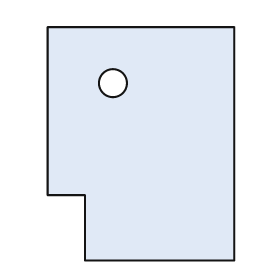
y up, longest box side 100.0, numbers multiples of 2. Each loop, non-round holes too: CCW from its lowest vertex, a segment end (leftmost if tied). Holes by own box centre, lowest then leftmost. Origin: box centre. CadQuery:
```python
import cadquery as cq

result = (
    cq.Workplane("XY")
    .moveTo(-24.0, -50.0)
    .lineTo(40.0, -50.0)
    .lineTo(40.0, 50.0)
    .lineTo(-40.0, 50.0)
    .lineTo(-40.0, -22.0)
    .lineTo(-24.0, -22.0)
    .close()
    .moveTo(-12.0, 26.0)
    .circle(6.0)
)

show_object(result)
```